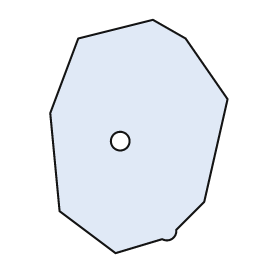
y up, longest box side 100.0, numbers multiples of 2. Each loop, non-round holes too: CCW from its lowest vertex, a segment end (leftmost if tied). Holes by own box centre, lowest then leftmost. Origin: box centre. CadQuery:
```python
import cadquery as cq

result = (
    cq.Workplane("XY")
    .moveTo(-10.0, -50.0)
    .lineTo(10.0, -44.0)
    .threePointArc((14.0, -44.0), (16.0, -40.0))
    .lineTo(28.0, -28.0)
    .lineTo(38.0, 16.0)
    .lineTo(20.0, 42.0)
    .lineTo(6.0, 50.0)
    .lineTo(-26.0, 42.0)
    .lineTo(-38.0, 10.0)
    .lineTo(-34.0, -32.0)
    .close()
    .moveTo(-8.0, -2.0)
    .circle(4.0)
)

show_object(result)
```